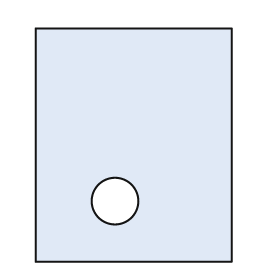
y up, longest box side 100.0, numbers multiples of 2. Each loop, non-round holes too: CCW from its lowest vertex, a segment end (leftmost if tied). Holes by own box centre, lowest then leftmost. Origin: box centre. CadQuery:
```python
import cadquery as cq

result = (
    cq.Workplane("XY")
    .moveTo(-42.0, -50.0)
    .lineTo(42.0, -50.0)
    .lineTo(42.0, 50.0)
    .lineTo(-42.0, 50.0)
    .close()
    .moveTo(-8.0, -24.0)
    .circle(10.0)
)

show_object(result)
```